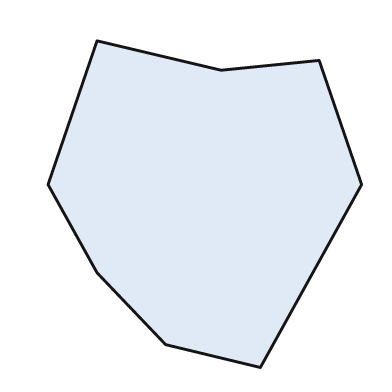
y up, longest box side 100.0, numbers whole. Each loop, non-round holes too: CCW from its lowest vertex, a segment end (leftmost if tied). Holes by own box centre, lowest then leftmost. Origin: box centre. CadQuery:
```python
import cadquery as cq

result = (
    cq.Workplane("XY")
    .moveTo(17.0, -50.0)
    .lineTo(48.0, 6.0)
    .lineTo(35.0, 44.0)
    .lineTo(5.0, 41.0)
    .lineTo(-33.0, 50.0)
    .lineTo(-48.0, 6.0)
    .lineTo(-33.0, -21.0)
    .lineTo(-12.0, -43.0)
    .close()
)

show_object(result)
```